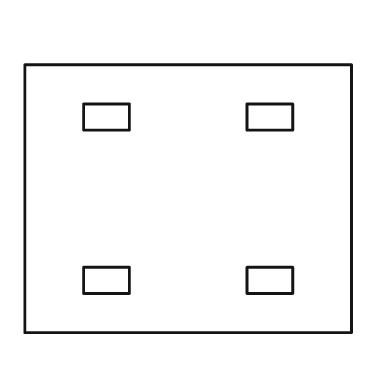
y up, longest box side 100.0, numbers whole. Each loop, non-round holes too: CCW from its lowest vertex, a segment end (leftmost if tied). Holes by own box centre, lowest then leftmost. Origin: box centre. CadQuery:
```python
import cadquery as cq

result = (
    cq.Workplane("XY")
    .moveTo(-50.0, -41.0)
    .lineTo(50.0, -41.0)
    .lineTo(50.0, 41.0)
    .lineTo(-50.0, 41.0)
    .close()
    .moveTo(-32.0, -29.0)
    .lineTo(-18.0, -29.0)
    .lineTo(-18.0, -21.0)
    .lineTo(-32.0, -21.0)
    .close()
    .moveTo(18.0, -29.0)
    .lineTo(32.0, -29.0)
    .lineTo(32.0, -21.0)
    .lineTo(18.0, -21.0)
    .close()
    .moveTo(-32.0, 21.0)
    .lineTo(-18.0, 21.0)
    .lineTo(-18.0, 29.0)
    .lineTo(-32.0, 29.0)
    .close()
    .moveTo(18.0, 21.0)
    .lineTo(32.0, 21.0)
    .lineTo(32.0, 29.0)
    .lineTo(18.0, 29.0)
    .close()
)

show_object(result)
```